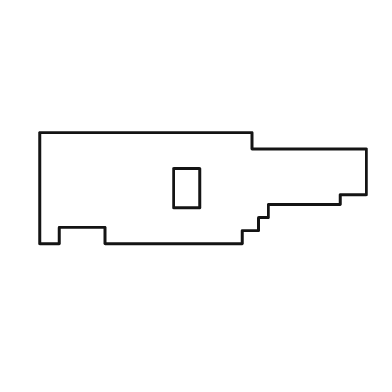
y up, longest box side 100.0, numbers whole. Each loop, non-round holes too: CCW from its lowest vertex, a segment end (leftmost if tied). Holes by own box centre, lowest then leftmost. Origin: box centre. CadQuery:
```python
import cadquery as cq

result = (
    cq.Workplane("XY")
    .moveTo(-50.0, -17.0)
    .lineTo(-44.0, -17.0)
    .lineTo(-44.0, -12.0)
    .lineTo(-30.0, -12.0)
    .lineTo(-30.0, -17.0)
    .lineTo(12.0, -17.0)
    .lineTo(12.0, -13.0)
    .lineTo(17.0, -13.0)
    .lineTo(17.0, -9.0)
    .lineTo(20.0, -9.0)
    .lineTo(20.0, -5.0)
    .lineTo(42.0, -5.0)
    .lineTo(42.0, -2.0)
    .lineTo(50.0, -2.0)
    .lineTo(50.0, 12.0)
    .lineTo(15.0, 12.0)
    .lineTo(15.0, 17.0)
    .lineTo(-50.0, 17.0)
    .close()
    .moveTo(-9.0, -6.0)
    .lineTo(-1.0, -6.0)
    .lineTo(-1.0, 6.0)
    .lineTo(-9.0, 6.0)
    .close()
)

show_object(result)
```